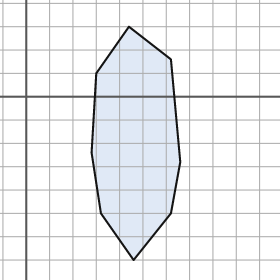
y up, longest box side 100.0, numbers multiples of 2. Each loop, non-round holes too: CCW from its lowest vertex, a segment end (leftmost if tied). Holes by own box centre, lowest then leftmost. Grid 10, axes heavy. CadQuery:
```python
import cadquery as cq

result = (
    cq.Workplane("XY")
    .moveTo(46.0, -70.0)
    .lineTo(62.0, -50.0)
    .lineTo(66.0, -28.0)
    .lineTo(62.0, 16.0)
    .lineTo(44.0, 30.0)
    .lineTo(30.0, 10.0)
    .lineTo(28.0, -24.0)
    .lineTo(32.0, -50.0)
    .close()
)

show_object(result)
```